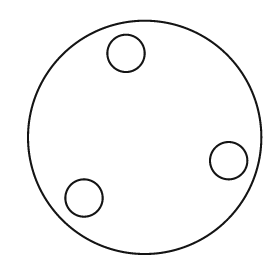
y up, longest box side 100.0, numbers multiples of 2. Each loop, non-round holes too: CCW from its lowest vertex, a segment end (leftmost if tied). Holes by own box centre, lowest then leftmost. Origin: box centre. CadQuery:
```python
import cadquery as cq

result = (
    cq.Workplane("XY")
    .moveTo(0.0, 0.0)
    .circle(50.0)
    .moveTo(-26.0, -26.0)
    .circle(8.0)
    .moveTo(36.0, -10.0)
    .circle(8.0)
    .moveTo(-8.0, 36.0)
    .circle(8.0)
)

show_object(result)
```